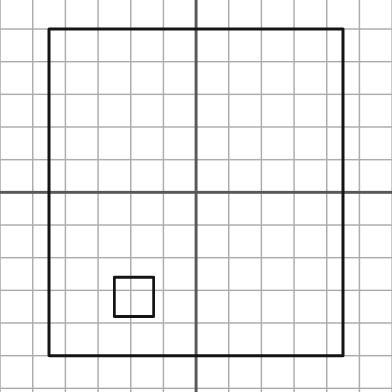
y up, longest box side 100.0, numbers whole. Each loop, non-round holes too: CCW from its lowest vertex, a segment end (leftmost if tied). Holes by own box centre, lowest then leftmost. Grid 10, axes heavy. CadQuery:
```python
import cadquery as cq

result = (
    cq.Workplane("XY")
    .moveTo(-45.0, -50.0)
    .lineTo(45.0, -50.0)
    .lineTo(45.0, 50.0)
    .lineTo(-45.0, 50.0)
    .close()
    .moveTo(-25.0, -38.0)
    .lineTo(-13.0, -38.0)
    .lineTo(-13.0, -26.0)
    .lineTo(-25.0, -26.0)
    .close()
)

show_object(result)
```